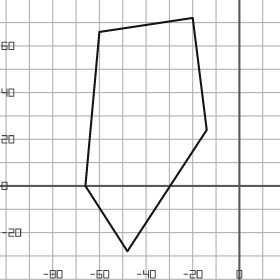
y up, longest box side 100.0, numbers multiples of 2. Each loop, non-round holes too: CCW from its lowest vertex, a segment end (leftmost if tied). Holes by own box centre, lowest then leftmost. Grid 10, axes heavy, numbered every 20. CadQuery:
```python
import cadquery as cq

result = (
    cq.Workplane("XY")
    .moveTo(-48.0, -28.0)
    .lineTo(-14.0, 24.0)
    .lineTo(-20.0, 72.0)
    .lineTo(-60.0, 66.0)
    .lineTo(-66.0, 0.0)
    .close()
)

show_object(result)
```